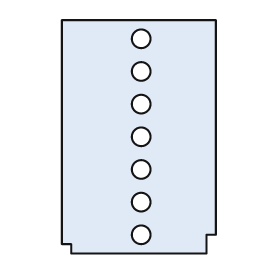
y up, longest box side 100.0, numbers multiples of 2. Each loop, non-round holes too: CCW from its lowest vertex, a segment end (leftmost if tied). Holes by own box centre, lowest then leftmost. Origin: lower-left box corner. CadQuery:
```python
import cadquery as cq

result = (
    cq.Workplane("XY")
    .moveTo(4.0, 0.0)
    .lineTo(62.0, 0.0)
    .lineTo(62.0, 8.0)
    .lineTo(66.0, 8.0)
    .lineTo(66.0, 100.0)
    .lineTo(0.0, 100.0)
    .lineTo(0.0, 4.0)
    .lineTo(4.0, 4.0)
    .close()
    .moveTo(34.0, 8.0)
    .circle(4.0)
    .moveTo(34.0, 22.0)
    .circle(4.0)
    .moveTo(34.0, 36.0)
    .circle(4.0)
    .moveTo(34.0, 50.0)
    .circle(4.0)
    .moveTo(34.0, 64.0)
    .circle(4.0)
    .moveTo(34.0, 78.0)
    .circle(4.0)
    .moveTo(34.0, 92.0)
    .circle(4.0)
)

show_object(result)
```